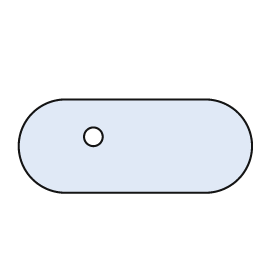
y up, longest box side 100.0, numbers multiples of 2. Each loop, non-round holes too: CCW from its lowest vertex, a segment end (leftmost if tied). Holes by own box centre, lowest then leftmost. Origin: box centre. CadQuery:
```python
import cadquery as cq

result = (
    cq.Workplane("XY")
    .moveTo(-30.0, -20.0)
    .lineTo(30.0, -20.0)
    .threePointArc((50.0, 0.0), (30.0, 20.0))
    .lineTo(-30.0, 20.0)
    .threePointArc((-50.0, 0.0), (-30.0, -20.0))
    .close()
    .moveTo(-18.0, 4.0)
    .circle(4.0)
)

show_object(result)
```